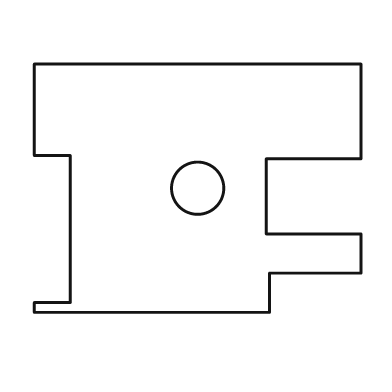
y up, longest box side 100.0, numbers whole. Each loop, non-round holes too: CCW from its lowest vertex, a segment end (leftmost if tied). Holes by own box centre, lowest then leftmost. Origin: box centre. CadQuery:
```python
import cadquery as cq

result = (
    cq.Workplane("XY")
    .moveTo(-50.0, -38.0)
    .lineTo(22.0, -38.0)
    .lineTo(22.0, -26.0)
    .lineTo(50.0, -26.0)
    .lineTo(50.0, -14.0)
    .lineTo(21.0, -14.0)
    .lineTo(21.0, 9.0)
    .lineTo(50.0, 9.0)
    .lineTo(50.0, 38.0)
    .lineTo(-50.0, 38.0)
    .lineTo(-50.0, 10.0)
    .lineTo(-39.0, 10.0)
    .lineTo(-39.0, -35.0)
    .lineTo(-50.0, -35.0)
    .close()
    .moveTo(0.0, 0.0)
    .circle(8.0)
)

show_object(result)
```